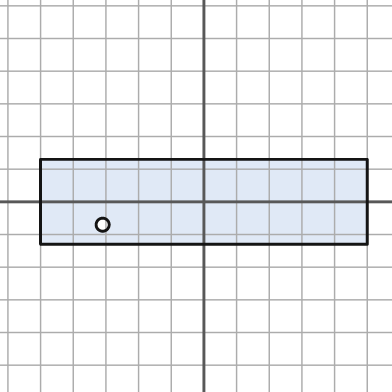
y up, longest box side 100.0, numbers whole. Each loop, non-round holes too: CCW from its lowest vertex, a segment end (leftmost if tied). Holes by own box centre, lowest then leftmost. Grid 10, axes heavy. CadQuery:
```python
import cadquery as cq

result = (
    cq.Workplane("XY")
    .moveTo(-50.0, -13.0)
    .lineTo(50.0, -13.0)
    .lineTo(50.0, 13.0)
    .lineTo(-50.0, 13.0)
    .close()
    .moveTo(-31.0, -7.0)
    .circle(2.0)
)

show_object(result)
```